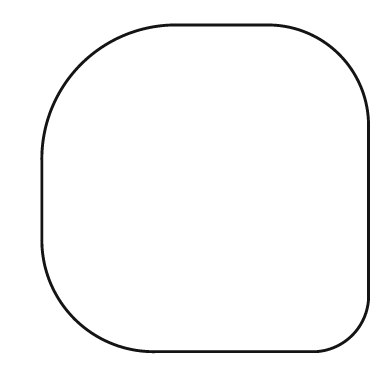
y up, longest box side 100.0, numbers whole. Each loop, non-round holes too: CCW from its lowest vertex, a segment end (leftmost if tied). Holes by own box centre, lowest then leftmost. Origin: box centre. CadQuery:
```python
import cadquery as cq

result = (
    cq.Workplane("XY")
    .moveTo(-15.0, -50.0)
    .lineTo(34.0, -50.0)
    .threePointArc((45.0, -45.0), (50.0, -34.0))
    .lineTo(50.0, 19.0)
    .threePointArc((41.0, 41.0), (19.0, 50.0))
    .lineTo(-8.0, 50.0)
    .threePointArc((-38.0, 38.0), (-50.0, 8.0))
    .lineTo(-50.0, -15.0)
    .threePointArc((-40.0, -40.0), (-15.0, -50.0))
    .close()
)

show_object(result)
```